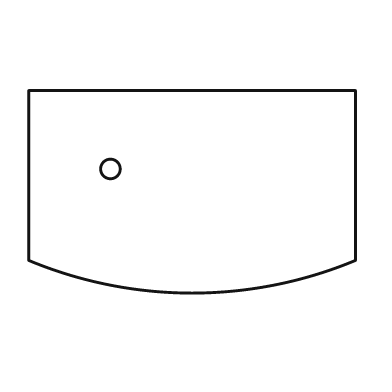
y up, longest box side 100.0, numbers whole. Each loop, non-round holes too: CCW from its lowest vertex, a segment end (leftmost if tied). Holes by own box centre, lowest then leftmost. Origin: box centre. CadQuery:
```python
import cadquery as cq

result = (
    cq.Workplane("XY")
    .moveTo(-50.0, -21.0)
    .threePointArc((0.0, -31.0), (50.0, -21.0))
    .lineTo(50.0, 31.0)
    .lineTo(-50.0, 31.0)
    .close()
    .moveTo(-25.0, 7.0)
    .circle(3.0)
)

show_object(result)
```